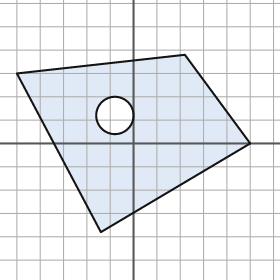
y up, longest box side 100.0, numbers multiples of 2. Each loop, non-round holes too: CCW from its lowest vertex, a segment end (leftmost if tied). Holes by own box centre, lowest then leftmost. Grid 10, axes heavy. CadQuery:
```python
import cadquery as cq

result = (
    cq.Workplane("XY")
    .moveTo(-14.0, -38.0)
    .lineTo(50.0, 0.0)
    .lineTo(22.0, 38.0)
    .lineTo(-50.0, 30.0)
    .close()
    .moveTo(-8.0, 12.0)
    .circle(8.0)
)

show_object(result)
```